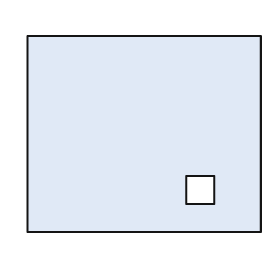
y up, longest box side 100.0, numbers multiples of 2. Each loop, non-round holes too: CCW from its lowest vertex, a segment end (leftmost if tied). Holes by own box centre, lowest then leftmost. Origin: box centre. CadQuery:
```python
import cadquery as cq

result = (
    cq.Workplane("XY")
    .moveTo(-50.0, -42.0)
    .lineTo(50.0, -42.0)
    .lineTo(50.0, 42.0)
    .lineTo(-50.0, 42.0)
    .close()
    .moveTo(18.0, -30.0)
    .lineTo(30.0, -30.0)
    .lineTo(30.0, -18.0)
    .lineTo(18.0, -18.0)
    .close()
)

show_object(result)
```